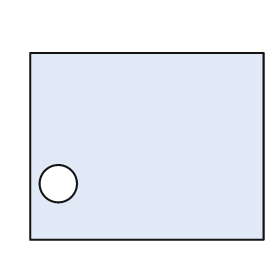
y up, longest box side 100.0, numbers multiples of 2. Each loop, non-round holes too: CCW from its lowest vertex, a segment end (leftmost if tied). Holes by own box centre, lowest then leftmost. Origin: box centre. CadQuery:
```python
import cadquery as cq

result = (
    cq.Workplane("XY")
    .moveTo(-50.0, -40.0)
    .lineTo(50.0, -40.0)
    .lineTo(50.0, 40.0)
    .lineTo(-50.0, 40.0)
    .close()
    .moveTo(-38.0, -16.0)
    .circle(8.0)
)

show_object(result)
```